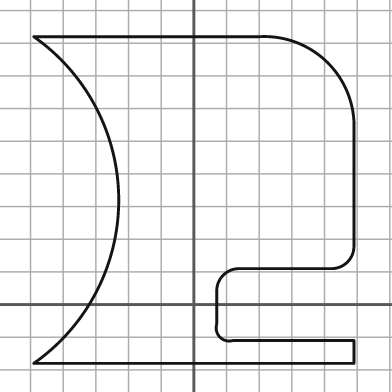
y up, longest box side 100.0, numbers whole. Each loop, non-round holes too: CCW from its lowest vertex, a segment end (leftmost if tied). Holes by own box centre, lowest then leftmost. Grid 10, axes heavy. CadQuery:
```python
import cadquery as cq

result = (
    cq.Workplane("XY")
    .moveTo(-49.0, -18.0)
    .lineTo(49.0, -18.0)
    .lineTo(49.0, -11.0)
    .lineTo(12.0, -11.0)
    .threePointArc((8.0, -10.0), (7.0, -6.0))
    .lineTo(7.0, 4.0)
    .threePointArc((9.0, 9.0), (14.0, 11.0))
    .lineTo(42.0, 11.0)
    .threePointArc((47.0, 13.0), (49.0, 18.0))
    .lineTo(49.0, 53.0)
    .threePointArc((41.0, 74.0), (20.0, 82.0))
    .lineTo(-49.0, 82.0)
    .threePointArc((-23.0, 32.0), (-49.0, -18.0))
    .close()
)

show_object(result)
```